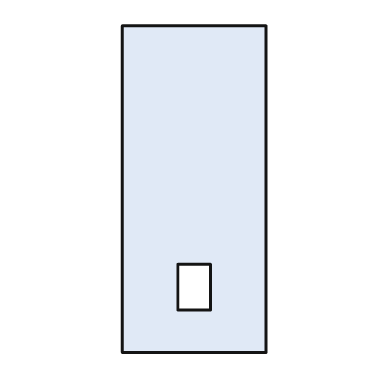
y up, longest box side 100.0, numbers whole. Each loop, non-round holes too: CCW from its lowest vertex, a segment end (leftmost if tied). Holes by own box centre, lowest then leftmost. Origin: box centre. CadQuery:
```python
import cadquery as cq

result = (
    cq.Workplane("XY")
    .moveTo(-22.0, -50.0)
    .lineTo(22.0, -50.0)
    .lineTo(22.0, 50.0)
    .lineTo(-22.0, 50.0)
    .close()
    .moveTo(-5.0, -37.0)
    .lineTo(5.0, -37.0)
    .lineTo(5.0, -23.0)
    .lineTo(-5.0, -23.0)
    .close()
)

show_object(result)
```